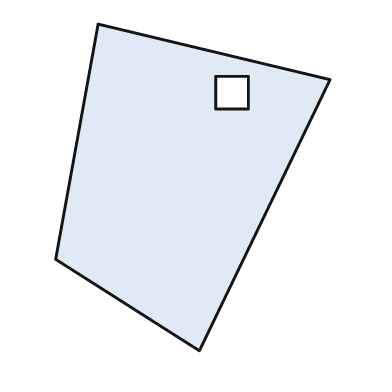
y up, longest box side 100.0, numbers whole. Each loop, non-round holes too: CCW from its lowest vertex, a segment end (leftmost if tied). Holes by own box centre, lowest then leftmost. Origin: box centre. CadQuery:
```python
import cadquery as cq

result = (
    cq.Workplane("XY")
    .moveTo(2.0, -50.0)
    .lineTo(42.0, 33.0)
    .lineTo(-29.0, 50.0)
    .lineTo(-42.0, -22.0)
    .close()
    .moveTo(7.0, 24.0)
    .lineTo(17.0, 24.0)
    .lineTo(17.0, 34.0)
    .lineTo(7.0, 34.0)
    .close()
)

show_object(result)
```